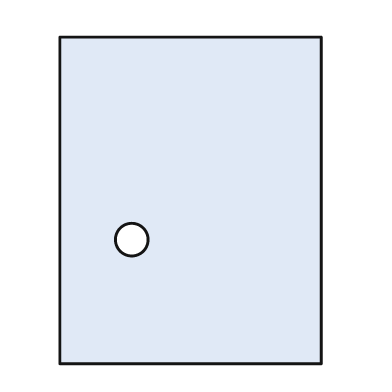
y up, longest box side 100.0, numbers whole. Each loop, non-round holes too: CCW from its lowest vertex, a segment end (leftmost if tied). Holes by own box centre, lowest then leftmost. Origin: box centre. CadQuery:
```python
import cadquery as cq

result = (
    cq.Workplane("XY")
    .moveTo(-40.0, -50.0)
    .lineTo(40.0, -50.0)
    .lineTo(40.0, 50.0)
    .lineTo(-40.0, 50.0)
    .close()
    .moveTo(-18.0, -12.0)
    .circle(5.0)
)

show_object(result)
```